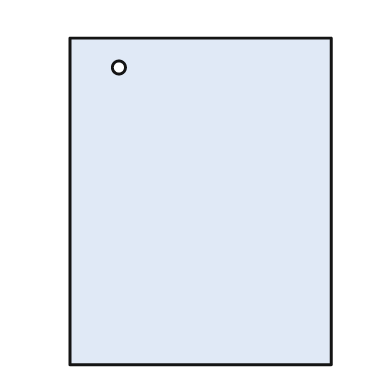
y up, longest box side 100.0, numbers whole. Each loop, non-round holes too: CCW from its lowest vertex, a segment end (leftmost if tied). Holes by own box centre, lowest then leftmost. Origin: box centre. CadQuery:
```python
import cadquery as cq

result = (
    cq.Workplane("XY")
    .moveTo(-40.0, -50.0)
    .lineTo(40.0, -50.0)
    .lineTo(40.0, 50.0)
    .lineTo(-40.0, 50.0)
    .close()
    .moveTo(-25.0, 41.0)
    .circle(2.0)
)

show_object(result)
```